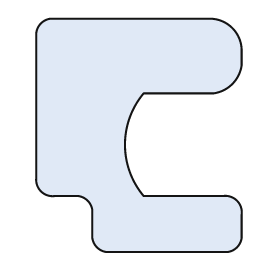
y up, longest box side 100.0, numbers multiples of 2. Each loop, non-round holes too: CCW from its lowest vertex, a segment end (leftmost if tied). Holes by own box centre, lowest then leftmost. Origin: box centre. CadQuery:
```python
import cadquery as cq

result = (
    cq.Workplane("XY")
    .moveTo(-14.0, -50.0)
    .lineTo(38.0, -50.0)
    .threePointArc((42.0, -48.0), (44.0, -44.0))
    .lineTo(44.0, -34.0)
    .threePointArc((42.0, -28.0), (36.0, -26.0))
    .lineTo(2.0, -26.0)
    .threePointArc((-6.0, -4.0), (2.0, 18.0))
    .lineTo(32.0, 18.0)
    .threePointArc((40.0, 22.0), (44.0, 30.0))
    .lineTo(44.0, 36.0)
    .threePointArc((40.0, 46.0), (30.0, 50.0))
    .lineTo(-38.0, 50.0)
    .threePointArc((-42.0, 48.0), (-44.0, 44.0))
    .lineTo(-44.0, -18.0)
    .threePointArc((-42.0, -24.0), (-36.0, -26.0))
    .lineTo(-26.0, -26.0)
    .threePointArc((-22.0, -28.0), (-20.0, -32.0))
    .lineTo(-20.0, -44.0)
    .threePointArc((-18.0, -48.0), (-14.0, -50.0))
    .close()
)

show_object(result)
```